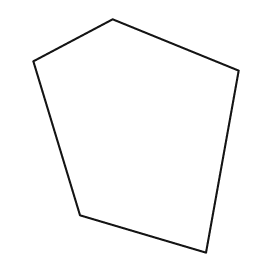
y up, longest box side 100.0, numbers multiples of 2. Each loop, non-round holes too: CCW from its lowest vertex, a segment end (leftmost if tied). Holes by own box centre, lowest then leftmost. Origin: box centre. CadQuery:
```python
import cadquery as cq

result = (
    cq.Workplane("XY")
    .moveTo(30.0, -50.0)
    .lineTo(44.0, 28.0)
    .lineTo(-10.0, 50.0)
    .lineTo(-44.0, 32.0)
    .lineTo(-24.0, -34.0)
    .close()
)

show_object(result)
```